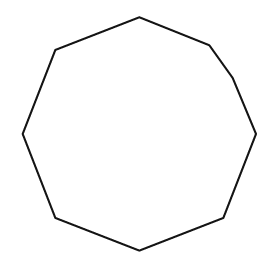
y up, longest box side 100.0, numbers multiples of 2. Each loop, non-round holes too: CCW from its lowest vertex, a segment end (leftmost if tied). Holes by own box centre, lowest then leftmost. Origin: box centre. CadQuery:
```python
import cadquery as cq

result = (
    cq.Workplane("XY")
    .moveTo(0.0, -50.0)
    .lineTo(36.0, -36.0)
    .lineTo(50.0, 0.0)
    .lineTo(40.0, 24.0)
    .lineTo(30.0, 38.0)
    .lineTo(0.0, 50.0)
    .lineTo(-36.0, 36.0)
    .lineTo(-50.0, 0.0)
    .lineTo(-36.0, -36.0)
    .close()
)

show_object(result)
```